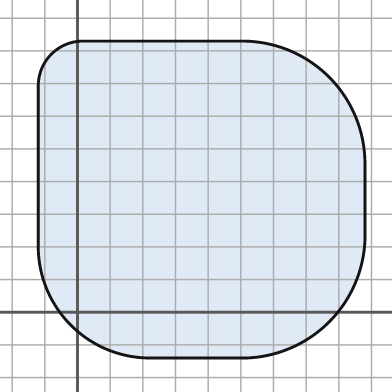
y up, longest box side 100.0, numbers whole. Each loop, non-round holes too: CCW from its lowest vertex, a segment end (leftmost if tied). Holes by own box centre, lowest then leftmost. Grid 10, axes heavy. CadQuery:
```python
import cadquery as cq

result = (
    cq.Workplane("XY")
    .moveTo(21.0, -14.0)
    .lineTo(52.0, -14.0)
    .threePointArc((77.0, -3.0), (88.0, 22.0))
    .lineTo(88.0, 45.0)
    .threePointArc((77.0, 72.0), (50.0, 83.0))
    .lineTo(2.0, 83.0)
    .threePointArc((-8.0, 79.0), (-12.0, 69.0))
    .lineTo(-12.0, 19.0)
    .threePointArc((-2.0, -4.0), (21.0, -14.0))
    .close()
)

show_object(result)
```